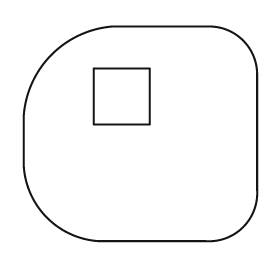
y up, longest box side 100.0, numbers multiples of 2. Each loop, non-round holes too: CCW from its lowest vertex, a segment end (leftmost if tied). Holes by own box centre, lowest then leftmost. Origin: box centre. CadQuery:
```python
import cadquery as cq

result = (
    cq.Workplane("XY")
    .moveTo(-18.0, -46.0)
    .lineTo(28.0, -46.0)
    .threePointArc((44.0, -40.0), (50.0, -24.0))
    .lineTo(50.0, 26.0)
    .threePointArc((44.0, 40.0), (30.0, 46.0))
    .lineTo(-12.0, 46.0)
    .threePointArc((-38.0, 34.0), (-50.0, 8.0))
    .lineTo(-50.0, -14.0)
    .threePointArc((-40.0, -36.0), (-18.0, -46.0))
    .close()
    .moveTo(-20.0, 4.0)
    .lineTo(4.0, 4.0)
    .lineTo(4.0, 28.0)
    .lineTo(-20.0, 28.0)
    .close()
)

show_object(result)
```